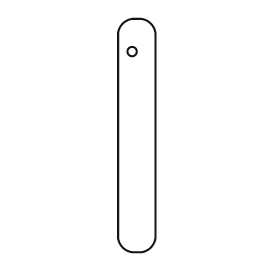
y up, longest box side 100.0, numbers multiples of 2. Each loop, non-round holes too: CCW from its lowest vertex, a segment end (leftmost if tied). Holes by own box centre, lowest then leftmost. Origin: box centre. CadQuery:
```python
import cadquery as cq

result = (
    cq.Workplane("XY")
    .moveTo(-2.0, -50.0)
    .lineTo(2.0, -50.0)
    .threePointArc((6.0, -48.0), (8.0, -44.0))
    .lineTo(8.0, 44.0)
    .threePointArc((6.0, 48.0), (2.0, 50.0))
    .lineTo(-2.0, 50.0)
    .threePointArc((-6.0, 48.0), (-8.0, 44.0))
    .lineTo(-8.0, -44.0)
    .threePointArc((-6.0, -48.0), (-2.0, -50.0))
    .close()
    .moveTo(-2.0, 36.0)
    .circle(2.0)
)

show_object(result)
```